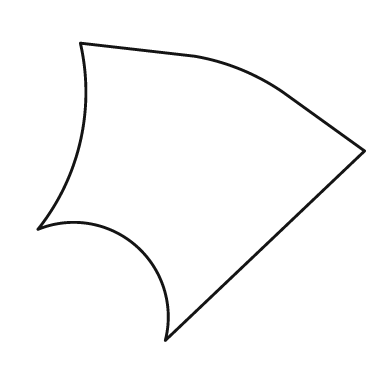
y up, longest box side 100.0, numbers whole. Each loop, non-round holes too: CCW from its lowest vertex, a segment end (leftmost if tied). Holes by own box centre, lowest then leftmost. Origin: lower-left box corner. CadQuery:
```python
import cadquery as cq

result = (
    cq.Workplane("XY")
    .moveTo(39.0, 0.0)
    .lineTo(100.0, 58.0)
    .lineTo(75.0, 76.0)
    .threePointArc((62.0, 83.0), (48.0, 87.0))
    .lineTo(13.0, 91.0)
    .threePointArc((13.0, 61.0), (0.0, 34.0))
    .threePointArc((30.0, 29.0), (39.0, 0.0))
    .close()
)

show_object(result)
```